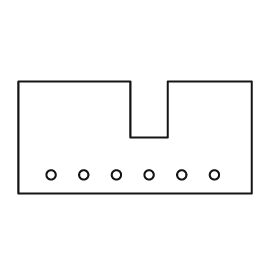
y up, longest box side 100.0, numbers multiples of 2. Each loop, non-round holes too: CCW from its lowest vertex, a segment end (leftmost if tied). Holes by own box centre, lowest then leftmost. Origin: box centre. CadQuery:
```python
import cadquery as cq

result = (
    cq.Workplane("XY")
    .moveTo(-50.0, -24.0)
    .lineTo(50.0, -24.0)
    .lineTo(50.0, 24.0)
    .lineTo(14.0, 24.0)
    .lineTo(14.0, 0.0)
    .lineTo(-2.0, 0.0)
    .lineTo(-2.0, 24.0)
    .lineTo(-50.0, 24.0)
    .close()
    .moveTo(-36.0, -16.0)
    .circle(2.0)
    .moveTo(-22.0, -16.0)
    .circle(2.0)
    .moveTo(-8.0, -16.0)
    .circle(2.0)
    .moveTo(6.0, -16.0)
    .circle(2.0)
    .moveTo(20.0, -16.0)
    .circle(2.0)
    .moveTo(34.0, -16.0)
    .circle(2.0)
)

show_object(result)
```